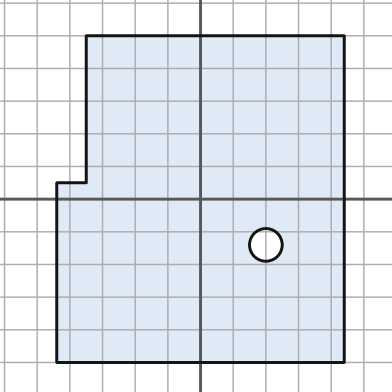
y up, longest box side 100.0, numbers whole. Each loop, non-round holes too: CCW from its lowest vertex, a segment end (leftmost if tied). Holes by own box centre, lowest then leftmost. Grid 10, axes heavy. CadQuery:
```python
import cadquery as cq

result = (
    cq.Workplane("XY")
    .moveTo(-44.0, -50.0)
    .lineTo(44.0, -50.0)
    .lineTo(44.0, 50.0)
    .lineTo(-35.0, 50.0)
    .lineTo(-35.0, 5.0)
    .lineTo(-44.0, 5.0)
    .close()
    .moveTo(20.0, -14.0)
    .circle(5.0)
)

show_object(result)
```